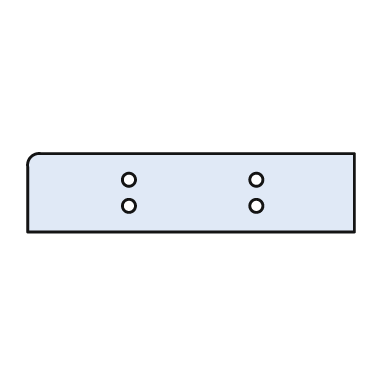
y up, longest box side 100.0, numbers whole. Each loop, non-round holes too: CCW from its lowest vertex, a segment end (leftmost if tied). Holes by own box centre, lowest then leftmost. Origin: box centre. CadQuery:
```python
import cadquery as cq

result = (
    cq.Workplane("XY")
    .moveTo(-50.0, -12.0)
    .lineTo(50.0, -12.0)
    .lineTo(50.0, 12.0)
    .lineTo(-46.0, 12.0)
    .threePointArc((-49.0, 11.0), (-50.0, 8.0))
    .close()
    .moveTo(-19.0, -4.0)
    .circle(2.0)
    .moveTo(20.0, -4.0)
    .circle(2.0)
    .moveTo(-19.0, 4.0)
    .circle(2.0)
    .moveTo(20.0, 4.0)
    .circle(2.0)
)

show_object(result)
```